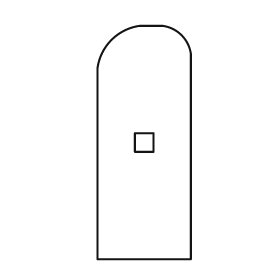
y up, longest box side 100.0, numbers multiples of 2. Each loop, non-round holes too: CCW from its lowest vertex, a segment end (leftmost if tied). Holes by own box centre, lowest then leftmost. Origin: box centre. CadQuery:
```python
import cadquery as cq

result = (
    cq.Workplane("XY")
    .moveTo(-20.0, -50.0)
    .lineTo(20.0, -50.0)
    .lineTo(20.0, 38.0)
    .threePointArc((16.0, 46.0), (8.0, 50.0))
    .lineTo(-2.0, 50.0)
    .threePointArc((-14.0, 44.0), (-20.0, 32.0))
    .close()
    .moveTo(-4.0, -4.0)
    .lineTo(4.0, -4.0)
    .lineTo(4.0, 4.0)
    .lineTo(-4.0, 4.0)
    .close()
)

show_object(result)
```